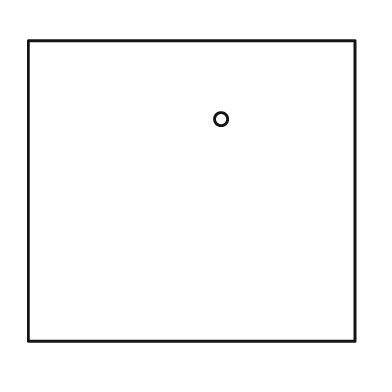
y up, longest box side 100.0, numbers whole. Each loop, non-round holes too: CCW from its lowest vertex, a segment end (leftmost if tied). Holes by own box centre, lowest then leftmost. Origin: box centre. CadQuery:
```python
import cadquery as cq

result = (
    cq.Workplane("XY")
    .moveTo(-50.0, -46.0)
    .lineTo(50.0, -46.0)
    .lineTo(50.0, 46.0)
    .lineTo(-50.0, 46.0)
    .close()
    .moveTo(9.0, 22.0)
    .circle(2.0)
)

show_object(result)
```